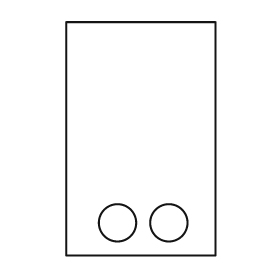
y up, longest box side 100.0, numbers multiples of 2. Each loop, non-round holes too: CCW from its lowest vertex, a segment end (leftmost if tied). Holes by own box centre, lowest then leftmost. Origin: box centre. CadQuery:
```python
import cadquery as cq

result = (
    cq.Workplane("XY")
    .moveTo(-32.0, -50.0)
    .lineTo(32.0, -50.0)
    .lineTo(32.0, 50.0)
    .lineTo(-32.0, 50.0)
    .close()
    .moveTo(-10.0, -36.0)
    .circle(8.0)
    .moveTo(12.0, -36.0)
    .circle(8.0)
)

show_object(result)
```